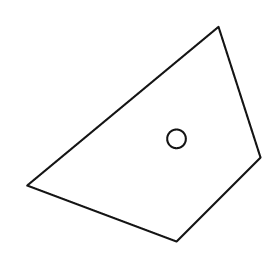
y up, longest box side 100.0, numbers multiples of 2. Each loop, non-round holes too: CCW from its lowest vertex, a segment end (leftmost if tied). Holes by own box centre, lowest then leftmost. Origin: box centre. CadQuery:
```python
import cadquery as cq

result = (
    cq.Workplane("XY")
    .moveTo(14.0, -46.0)
    .lineTo(50.0, -10.0)
    .lineTo(32.0, 46.0)
    .lineTo(-50.0, -22.0)
    .close()
    .moveTo(14.0, -2.0)
    .circle(4.0)
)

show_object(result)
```